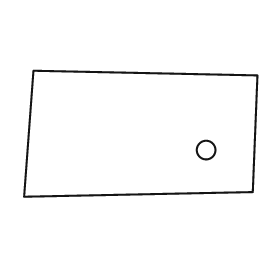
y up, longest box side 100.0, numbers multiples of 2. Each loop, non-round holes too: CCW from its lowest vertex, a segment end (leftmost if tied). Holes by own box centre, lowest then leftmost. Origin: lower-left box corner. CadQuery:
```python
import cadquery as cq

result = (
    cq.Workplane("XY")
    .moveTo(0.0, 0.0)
    .lineTo(98.0, 2.0)
    .lineTo(100.0, 52.0)
    .lineTo(4.0, 54.0)
    .close()
    .moveTo(78.0, 20.0)
    .circle(4.0)
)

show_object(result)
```